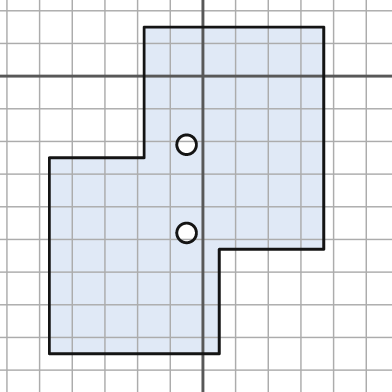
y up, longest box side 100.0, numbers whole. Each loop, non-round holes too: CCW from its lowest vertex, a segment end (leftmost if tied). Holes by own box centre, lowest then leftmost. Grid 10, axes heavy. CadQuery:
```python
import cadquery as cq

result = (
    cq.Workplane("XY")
    .moveTo(-47.0, -85.0)
    .lineTo(5.0, -85.0)
    .lineTo(5.0, -53.0)
    .lineTo(37.0, -53.0)
    .lineTo(37.0, 15.0)
    .lineTo(-18.0, 15.0)
    .lineTo(-18.0, -25.0)
    .lineTo(-47.0, -25.0)
    .close()
    .moveTo(-5.0, -48.0)
    .circle(3.0)
    .moveTo(-5.0, -21.0)
    .circle(3.0)
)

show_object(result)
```